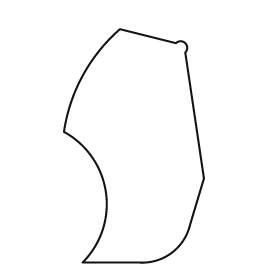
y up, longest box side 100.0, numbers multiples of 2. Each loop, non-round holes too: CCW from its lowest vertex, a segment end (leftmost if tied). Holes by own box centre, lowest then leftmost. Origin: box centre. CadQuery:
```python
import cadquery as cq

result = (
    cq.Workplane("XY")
    .moveTo(-22.0, -50.0)
    .lineTo(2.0, -50.0)
    .threePointArc((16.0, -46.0), (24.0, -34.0))
    .lineTo(30.0, -14.0)
    .lineTo(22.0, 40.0)
    .threePointArc((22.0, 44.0), (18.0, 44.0))
    .lineTo(-6.0, 50.0)
    .threePointArc((-22.0, 30.0), (-30.0, 6.0))
    .threePointArc((-12.0, -20.0), (-22.0, -50.0))
    .close()
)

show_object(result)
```